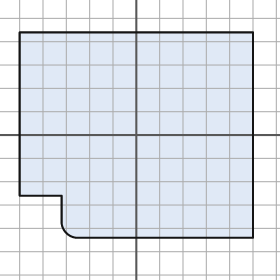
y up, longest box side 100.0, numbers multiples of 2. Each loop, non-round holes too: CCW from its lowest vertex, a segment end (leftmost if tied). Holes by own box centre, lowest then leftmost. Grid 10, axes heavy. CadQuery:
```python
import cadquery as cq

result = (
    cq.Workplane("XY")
    .moveTo(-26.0, -44.0)
    .lineTo(50.0, -44.0)
    .lineTo(50.0, 44.0)
    .lineTo(-50.0, 44.0)
    .lineTo(-50.0, -26.0)
    .lineTo(-32.0, -26.0)
    .lineTo(-32.0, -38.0)
    .threePointArc((-30.0, -42.0), (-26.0, -44.0))
    .close()
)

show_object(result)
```